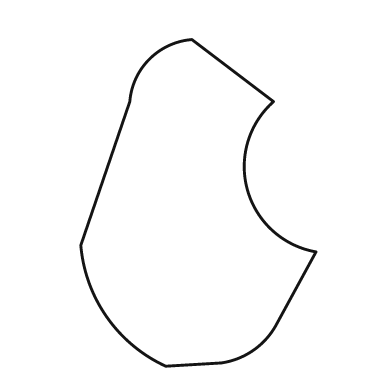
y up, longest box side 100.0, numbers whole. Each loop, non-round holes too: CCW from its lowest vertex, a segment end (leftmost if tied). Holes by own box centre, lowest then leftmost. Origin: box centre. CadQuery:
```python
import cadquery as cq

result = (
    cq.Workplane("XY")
    .moveTo(-10.0, -50.0)
    .lineTo(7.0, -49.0)
    .threePointArc((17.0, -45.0), (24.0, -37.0))
    .lineTo(36.0, -15.0)
    .threePointArc((15.0, 4.0), (23.0, 31.0))
    .lineTo(-2.0, 50.0)
    .threePointArc((-15.0, 44.0), (-21.0, 31.0))
    .lineTo(-36.0, -13.0)
    .threePointArc((-28.0, -35.0), (-10.0, -50.0))
    .close()
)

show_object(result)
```